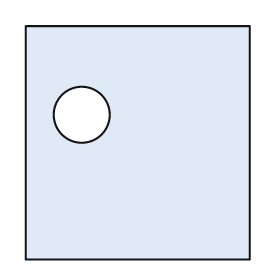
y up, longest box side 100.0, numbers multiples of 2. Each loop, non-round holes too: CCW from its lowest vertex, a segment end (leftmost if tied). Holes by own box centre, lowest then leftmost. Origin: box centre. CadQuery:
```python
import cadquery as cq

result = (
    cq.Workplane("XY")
    .moveTo(-48.0, -50.0)
    .lineTo(48.0, -50.0)
    .lineTo(48.0, 50.0)
    .lineTo(-48.0, 50.0)
    .close()
    .moveTo(-24.0, 12.0)
    .circle(12.0)
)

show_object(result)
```